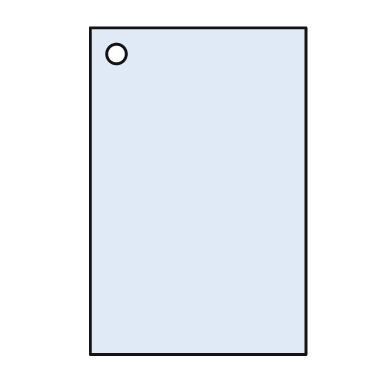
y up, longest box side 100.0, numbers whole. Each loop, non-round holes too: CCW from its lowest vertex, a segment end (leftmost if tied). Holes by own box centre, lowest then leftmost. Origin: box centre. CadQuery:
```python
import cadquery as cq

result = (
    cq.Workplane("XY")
    .moveTo(-33.0, -50.0)
    .lineTo(33.0, -50.0)
    .lineTo(33.0, 50.0)
    .lineTo(-33.0, 50.0)
    .close()
    .moveTo(-25.0, 42.0)
    .circle(3.0)
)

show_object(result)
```